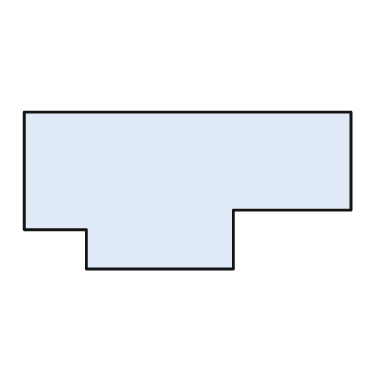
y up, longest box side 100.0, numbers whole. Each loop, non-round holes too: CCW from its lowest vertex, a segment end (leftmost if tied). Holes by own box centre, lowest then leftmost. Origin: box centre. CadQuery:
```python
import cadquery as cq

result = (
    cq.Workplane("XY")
    .moveTo(-31.0, -24.0)
    .lineTo(14.0, -24.0)
    .lineTo(14.0, -6.0)
    .lineTo(50.0, -6.0)
    .lineTo(50.0, 24.0)
    .lineTo(-50.0, 24.0)
    .lineTo(-50.0, -12.0)
    .lineTo(-31.0, -12.0)
    .close()
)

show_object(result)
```